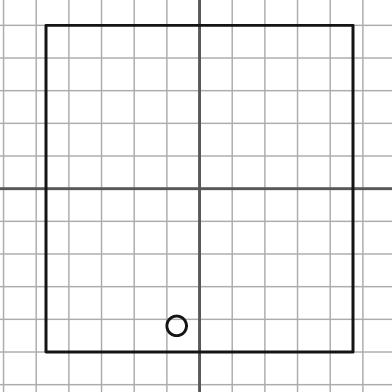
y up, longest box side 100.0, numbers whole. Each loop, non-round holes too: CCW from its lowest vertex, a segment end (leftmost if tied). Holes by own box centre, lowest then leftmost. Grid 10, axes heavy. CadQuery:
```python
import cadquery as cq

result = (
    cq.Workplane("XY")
    .moveTo(-47.0, -50.0)
    .lineTo(47.0, -50.0)
    .lineTo(47.0, 50.0)
    .lineTo(-47.0, 50.0)
    .close()
    .moveTo(-7.0, -42.0)
    .circle(3.0)
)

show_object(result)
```